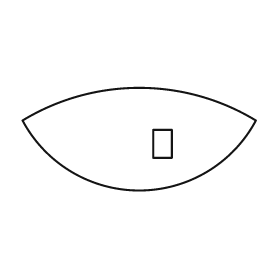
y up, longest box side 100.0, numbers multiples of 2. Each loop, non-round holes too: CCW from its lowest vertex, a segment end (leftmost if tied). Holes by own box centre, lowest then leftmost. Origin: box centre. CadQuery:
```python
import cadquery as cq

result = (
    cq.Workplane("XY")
    .moveTo(-50.0, 8.0)
    .threePointArc((0.0, -22.0), (50.0, 8.0))
    .threePointArc((0.0, 22.0), (-50.0, 8.0))
    .close()
    .moveTo(6.0, -8.0)
    .lineTo(14.0, -8.0)
    .lineTo(14.0, 4.0)
    .lineTo(6.0, 4.0)
    .close()
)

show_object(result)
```